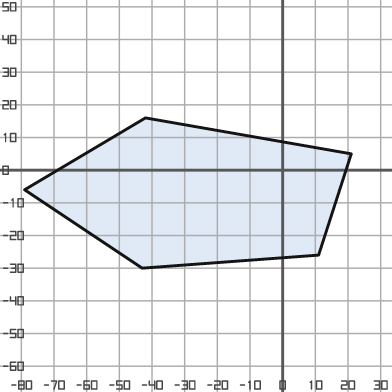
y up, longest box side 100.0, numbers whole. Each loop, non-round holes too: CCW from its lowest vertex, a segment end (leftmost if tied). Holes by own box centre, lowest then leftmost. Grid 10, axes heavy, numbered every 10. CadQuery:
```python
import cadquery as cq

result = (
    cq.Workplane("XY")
    .moveTo(-43.0, -30.0)
    .lineTo(11.0, -26.0)
    .lineTo(21.0, 5.0)
    .lineTo(-42.0, 16.0)
    .lineTo(-79.0, -6.0)
    .close()
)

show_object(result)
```